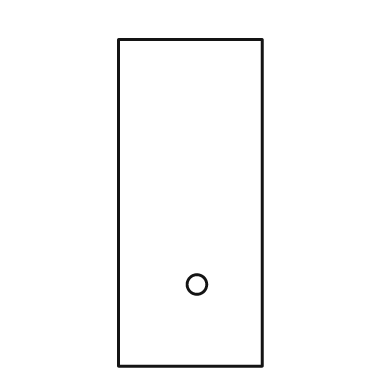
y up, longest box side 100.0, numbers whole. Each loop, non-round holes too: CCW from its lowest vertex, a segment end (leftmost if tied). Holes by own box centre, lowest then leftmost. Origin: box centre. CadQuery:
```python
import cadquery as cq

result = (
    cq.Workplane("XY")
    .moveTo(-22.0, -50.0)
    .lineTo(22.0, -50.0)
    .lineTo(22.0, 50.0)
    .lineTo(-22.0, 50.0)
    .close()
    .moveTo(2.0, -25.0)
    .circle(3.0)
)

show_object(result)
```